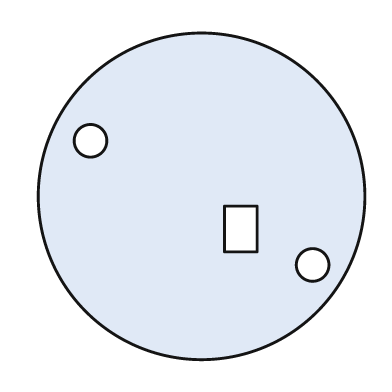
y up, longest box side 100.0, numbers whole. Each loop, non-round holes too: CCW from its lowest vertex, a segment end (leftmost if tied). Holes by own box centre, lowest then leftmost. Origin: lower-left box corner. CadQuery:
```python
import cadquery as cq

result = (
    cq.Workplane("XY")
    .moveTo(50.0, 50.0)
    .circle(50.0)
    .moveTo(84.0, 29.0)
    .circle(5.0)
    .moveTo(57.0, 33.0)
    .lineTo(67.0, 33.0)
    .lineTo(67.0, 47.0)
    .lineTo(57.0, 47.0)
    .close()
    .moveTo(16.0, 67.0)
    .circle(5.0)
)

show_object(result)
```